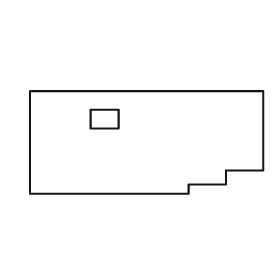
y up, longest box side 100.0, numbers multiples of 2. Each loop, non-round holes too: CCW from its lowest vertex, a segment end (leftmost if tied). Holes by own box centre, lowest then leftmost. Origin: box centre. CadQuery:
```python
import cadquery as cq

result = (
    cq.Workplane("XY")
    .moveTo(-50.0, -22.0)
    .lineTo(18.0, -22.0)
    .lineTo(18.0, -18.0)
    .lineTo(34.0, -18.0)
    .lineTo(34.0, -12.0)
    .lineTo(50.0, -12.0)
    .lineTo(50.0, 22.0)
    .lineTo(-50.0, 22.0)
    .close()
    .moveTo(-24.0, 6.0)
    .lineTo(-12.0, 6.0)
    .lineTo(-12.0, 14.0)
    .lineTo(-24.0, 14.0)
    .close()
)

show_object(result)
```